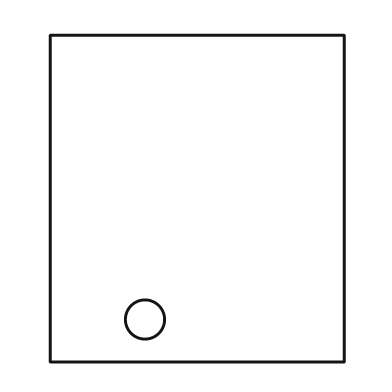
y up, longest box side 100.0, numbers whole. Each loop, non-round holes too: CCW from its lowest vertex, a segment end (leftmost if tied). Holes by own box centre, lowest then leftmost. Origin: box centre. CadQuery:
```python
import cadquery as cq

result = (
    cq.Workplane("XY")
    .moveTo(-45.0, -50.0)
    .lineTo(45.0, -50.0)
    .lineTo(45.0, 50.0)
    .lineTo(-45.0, 50.0)
    .close()
    .moveTo(-16.0, -37.0)
    .circle(6.0)
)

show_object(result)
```